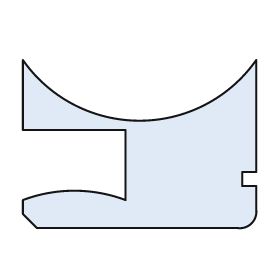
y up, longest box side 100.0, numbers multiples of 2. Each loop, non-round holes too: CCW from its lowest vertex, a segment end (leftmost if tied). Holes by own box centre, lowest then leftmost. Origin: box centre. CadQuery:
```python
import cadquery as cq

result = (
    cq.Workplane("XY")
    .moveTo(-44.0, -36.0)
    .lineTo(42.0, -36.0)
    .threePointArc((48.0, -34.0), (50.0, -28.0))
    .lineTo(50.0, -18.0)
    .lineTo(44.0, -18.0)
    .lineTo(44.0, -12.0)
    .lineTo(50.0, -12.0)
    .lineTo(50.0, 36.0)
    .threePointArc((0.0, 10.0), (-50.0, 36.0))
    .lineTo(-50.0, 6.0)
    .lineTo(-6.0, 6.0)
    .lineTo(-6.0, -24.0)
    .threePointArc((-28.0, -20.0), (-50.0, -24.0))
    .lineTo(-50.0, -30.0)
    .close()
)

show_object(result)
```